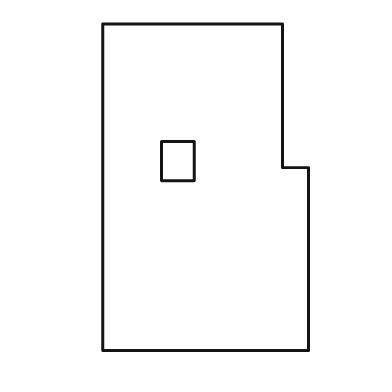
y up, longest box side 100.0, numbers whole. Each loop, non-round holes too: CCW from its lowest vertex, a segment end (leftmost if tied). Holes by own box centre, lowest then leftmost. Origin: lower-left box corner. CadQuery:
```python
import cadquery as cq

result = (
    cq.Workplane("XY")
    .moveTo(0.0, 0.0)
    .lineTo(63.0, 0.0)
    .lineTo(63.0, 56.0)
    .lineTo(55.0, 56.0)
    .lineTo(55.0, 100.0)
    .lineTo(0.0, 100.0)
    .close()
    .moveTo(18.0, 52.0)
    .lineTo(28.0, 52.0)
    .lineTo(28.0, 64.0)
    .lineTo(18.0, 64.0)
    .close()
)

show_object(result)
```